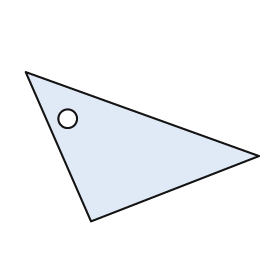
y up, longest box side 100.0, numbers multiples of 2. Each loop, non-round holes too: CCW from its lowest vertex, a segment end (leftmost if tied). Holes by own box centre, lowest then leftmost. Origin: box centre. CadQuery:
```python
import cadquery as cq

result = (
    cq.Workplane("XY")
    .moveTo(-22.0, -32.0)
    .lineTo(50.0, -4.0)
    .lineTo(-50.0, 32.0)
    .close()
    .moveTo(-32.0, 12.0)
    .circle(4.0)
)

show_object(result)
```